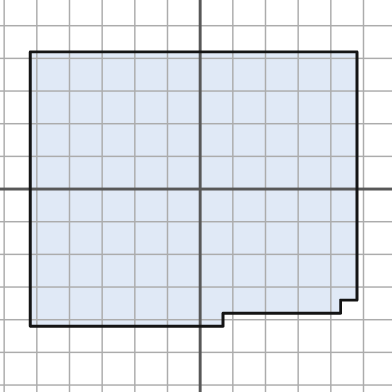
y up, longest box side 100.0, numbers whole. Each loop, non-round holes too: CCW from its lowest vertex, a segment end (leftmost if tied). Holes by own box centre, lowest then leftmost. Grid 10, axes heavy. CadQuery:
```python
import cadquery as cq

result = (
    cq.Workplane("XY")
    .moveTo(-52.0, -42.0)
    .lineTo(7.0, -42.0)
    .lineTo(7.0, -38.0)
    .lineTo(43.0, -38.0)
    .lineTo(43.0, -34.0)
    .lineTo(48.0, -34.0)
    .lineTo(48.0, 42.0)
    .lineTo(-52.0, 42.0)
    .close()
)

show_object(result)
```